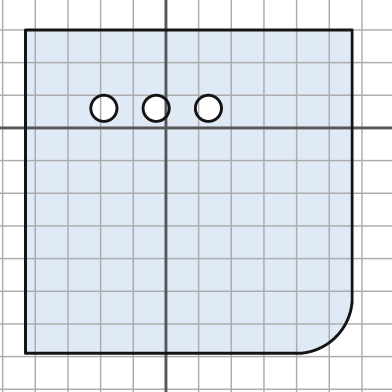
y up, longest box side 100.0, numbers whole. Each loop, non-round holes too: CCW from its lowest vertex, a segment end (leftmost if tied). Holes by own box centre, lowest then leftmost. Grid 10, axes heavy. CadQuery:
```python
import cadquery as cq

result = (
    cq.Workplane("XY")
    .moveTo(-43.0, -69.0)
    .lineTo(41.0, -69.0)
    .threePointArc((52.0, -64.0), (57.0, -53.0))
    .lineTo(57.0, 30.0)
    .lineTo(-43.0, 30.0)
    .close()
    .moveTo(-19.0, 6.0)
    .circle(4.0)
    .moveTo(-3.0, 6.0)
    .circle(4.0)
    .moveTo(13.0, 6.0)
    .circle(4.0)
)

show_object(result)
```